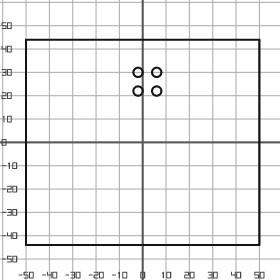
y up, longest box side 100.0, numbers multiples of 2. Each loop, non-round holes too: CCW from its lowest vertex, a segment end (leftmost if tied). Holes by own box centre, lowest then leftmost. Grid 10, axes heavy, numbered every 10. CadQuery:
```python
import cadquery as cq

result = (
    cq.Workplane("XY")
    .moveTo(-50.0, -44.0)
    .lineTo(50.0, -44.0)
    .lineTo(50.0, 44.0)
    .lineTo(-50.0, 44.0)
    .close()
    .moveTo(-2.0, 22.0)
    .circle(2.0)
    .moveTo(6.0, 22.0)
    .circle(2.0)
    .moveTo(-2.0, 30.0)
    .circle(2.0)
    .moveTo(6.0, 30.0)
    .circle(2.0)
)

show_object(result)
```